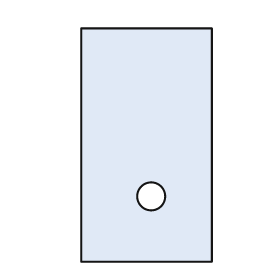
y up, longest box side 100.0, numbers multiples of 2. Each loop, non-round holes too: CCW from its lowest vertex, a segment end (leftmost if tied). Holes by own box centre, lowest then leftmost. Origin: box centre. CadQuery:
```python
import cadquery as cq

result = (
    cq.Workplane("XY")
    .moveTo(-28.0, -50.0)
    .lineTo(28.0, -50.0)
    .lineTo(28.0, 50.0)
    .lineTo(-28.0, 50.0)
    .close()
    .moveTo(2.0, -22.0)
    .circle(6.0)
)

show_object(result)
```